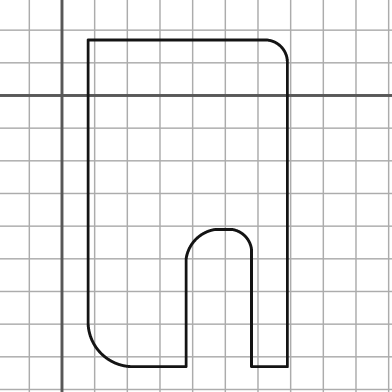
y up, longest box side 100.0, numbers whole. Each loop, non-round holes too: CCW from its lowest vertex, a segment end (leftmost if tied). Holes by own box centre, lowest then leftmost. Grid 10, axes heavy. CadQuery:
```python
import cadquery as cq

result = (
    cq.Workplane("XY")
    .moveTo(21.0, -83.0)
    .lineTo(38.0, -83.0)
    .lineTo(38.0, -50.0)
    .threePointArc((41.0, -44.0), (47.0, -41.0))
    .lineTo(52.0, -41.0)
    .threePointArc((56.0, -43.0), (58.0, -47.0))
    .lineTo(58.0, -83.0)
    .lineTo(69.0, -83.0)
    .lineTo(69.0, 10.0)
    .threePointArc((67.0, 15.0), (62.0, 17.0))
    .lineTo(8.0, 17.0)
    .lineTo(8.0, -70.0)
    .threePointArc((12.0, -79.0), (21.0, -83.0))
    .close()
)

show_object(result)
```